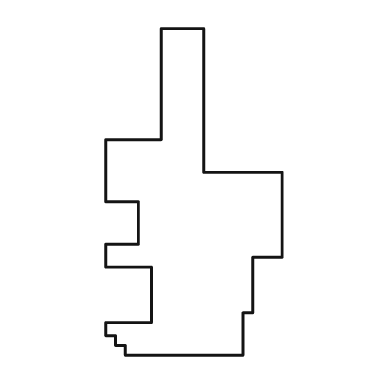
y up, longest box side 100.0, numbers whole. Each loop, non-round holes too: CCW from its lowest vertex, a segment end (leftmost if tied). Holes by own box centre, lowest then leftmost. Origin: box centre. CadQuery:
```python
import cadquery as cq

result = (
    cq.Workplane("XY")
    .moveTo(-21.0, -50.0)
    .lineTo(15.0, -50.0)
    .lineTo(15.0, -37.0)
    .lineTo(18.0, -37.0)
    .lineTo(18.0, -20.0)
    .lineTo(27.0, -20.0)
    .lineTo(27.0, 6.0)
    .lineTo(3.0, 6.0)
    .lineTo(3.0, 50.0)
    .lineTo(-10.0, 50.0)
    .lineTo(-10.0, 16.0)
    .lineTo(-27.0, 16.0)
    .lineTo(-27.0, -3.0)
    .lineTo(-17.0, -3.0)
    .lineTo(-17.0, -16.0)
    .lineTo(-27.0, -16.0)
    .lineTo(-27.0, -23.0)
    .lineTo(-13.0, -23.0)
    .lineTo(-13.0, -40.0)
    .lineTo(-27.0, -40.0)
    .lineTo(-27.0, -44.0)
    .lineTo(-24.0, -44.0)
    .lineTo(-24.0, -47.0)
    .lineTo(-21.0, -47.0)
    .close()
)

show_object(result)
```